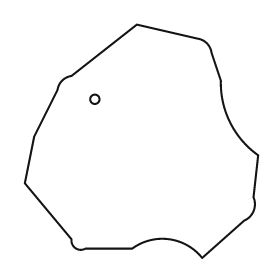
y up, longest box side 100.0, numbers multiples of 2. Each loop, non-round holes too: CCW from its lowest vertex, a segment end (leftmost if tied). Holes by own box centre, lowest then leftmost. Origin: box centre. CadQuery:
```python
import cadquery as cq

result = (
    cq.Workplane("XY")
    .moveTo(26.0, -50.0)
    .lineTo(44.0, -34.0)
    .threePointArc((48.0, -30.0), (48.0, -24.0))
    .lineTo(50.0, -6.0)
    .threePointArc((38.0, 8.0), (34.0, 26.0))
    .lineTo(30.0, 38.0)
    .threePointArc((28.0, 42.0), (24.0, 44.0))
    .lineTo(-2.0, 50.0)
    .lineTo(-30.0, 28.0)
    .threePointArc((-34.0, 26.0), (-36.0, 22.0))
    .lineTo(-46.0, 2.0)
    .lineTo(-50.0, -18.0)
    .lineTo(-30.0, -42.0)
    .threePointArc((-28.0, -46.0), (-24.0, -46.0))
    .lineTo(-4.0, -46.0)
    .threePointArc((12.0, -42.0), (26.0, -50.0))
    .close()
    .moveTo(-20.0, 18.0)
    .circle(2.0)
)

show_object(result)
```